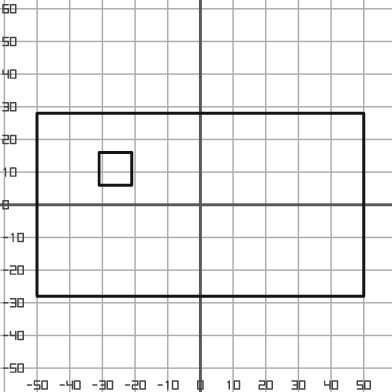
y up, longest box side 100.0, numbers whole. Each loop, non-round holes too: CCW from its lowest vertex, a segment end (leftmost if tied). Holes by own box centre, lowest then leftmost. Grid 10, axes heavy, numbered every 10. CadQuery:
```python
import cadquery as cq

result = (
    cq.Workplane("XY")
    .moveTo(-50.0, -28.0)
    .lineTo(50.0, -28.0)
    .lineTo(50.0, 28.0)
    .lineTo(-50.0, 28.0)
    .close()
    .moveTo(-31.0, 6.0)
    .lineTo(-21.0, 6.0)
    .lineTo(-21.0, 16.0)
    .lineTo(-31.0, 16.0)
    .close()
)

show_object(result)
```